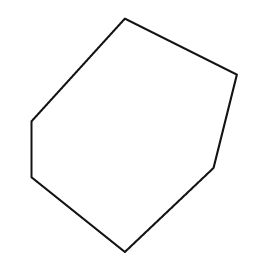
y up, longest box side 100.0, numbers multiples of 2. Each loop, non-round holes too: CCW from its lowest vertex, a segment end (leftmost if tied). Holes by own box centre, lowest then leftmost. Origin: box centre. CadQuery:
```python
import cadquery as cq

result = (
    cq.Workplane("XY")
    .moveTo(-4.0, -50.0)
    .lineTo(34.0, -14.0)
    .lineTo(44.0, 26.0)
    .lineTo(-4.0, 50.0)
    .lineTo(-44.0, 6.0)
    .lineTo(-44.0, -18.0)
    .close()
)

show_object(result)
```